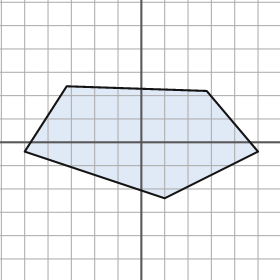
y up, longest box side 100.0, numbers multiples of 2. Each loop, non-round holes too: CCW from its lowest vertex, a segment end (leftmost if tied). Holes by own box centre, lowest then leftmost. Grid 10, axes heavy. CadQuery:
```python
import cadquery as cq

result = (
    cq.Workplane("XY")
    .moveTo(10.0, -24.0)
    .lineTo(50.0, -4.0)
    .lineTo(28.0, 22.0)
    .lineTo(-32.0, 24.0)
    .lineTo(-50.0, -4.0)
    .close()
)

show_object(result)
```